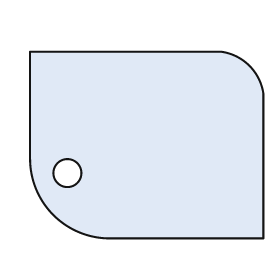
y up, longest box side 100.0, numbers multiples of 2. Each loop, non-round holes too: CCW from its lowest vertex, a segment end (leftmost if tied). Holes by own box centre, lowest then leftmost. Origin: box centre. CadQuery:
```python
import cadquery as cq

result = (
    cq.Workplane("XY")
    .moveTo(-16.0, -40.0)
    .lineTo(50.0, -40.0)
    .lineTo(50.0, 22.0)
    .threePointArc((44.0, 34.0), (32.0, 40.0))
    .lineTo(-50.0, 40.0)
    .lineTo(-50.0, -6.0)
    .threePointArc((-40.0, -30.0), (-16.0, -40.0))
    .close()
    .moveTo(-34.0, -12.0)
    .circle(6.0)
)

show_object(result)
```